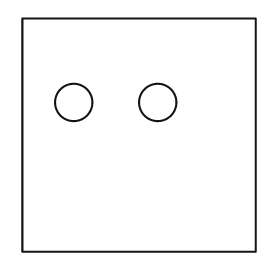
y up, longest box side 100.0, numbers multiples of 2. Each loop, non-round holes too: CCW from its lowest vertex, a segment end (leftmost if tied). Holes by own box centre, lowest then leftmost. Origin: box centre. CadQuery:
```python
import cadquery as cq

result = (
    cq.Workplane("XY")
    .moveTo(-50.0, -50.0)
    .lineTo(50.0, -50.0)
    .lineTo(50.0, 50.0)
    .lineTo(-50.0, 50.0)
    .close()
    .moveTo(-28.0, 14.0)
    .circle(8.0)
    .moveTo(8.0, 14.0)
    .circle(8.0)
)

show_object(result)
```